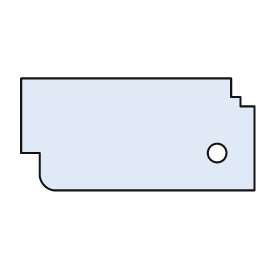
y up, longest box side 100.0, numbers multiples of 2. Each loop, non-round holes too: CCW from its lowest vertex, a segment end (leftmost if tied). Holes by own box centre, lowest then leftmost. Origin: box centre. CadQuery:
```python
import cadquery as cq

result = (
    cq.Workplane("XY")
    .moveTo(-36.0, -24.0)
    .lineTo(50.0, -24.0)
    .lineTo(50.0, 12.0)
    .lineTo(44.0, 12.0)
    .lineTo(44.0, 16.0)
    .lineTo(40.0, 16.0)
    .lineTo(40.0, 24.0)
    .lineTo(-50.0, 24.0)
    .lineTo(-50.0, -8.0)
    .lineTo(-42.0, -8.0)
    .lineTo(-42.0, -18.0)
    .threePointArc((-40.0, -22.0), (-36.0, -24.0))
    .close()
    .moveTo(34.0, -8.0)
    .circle(4.0)
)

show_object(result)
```